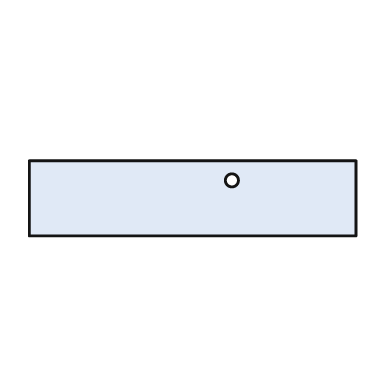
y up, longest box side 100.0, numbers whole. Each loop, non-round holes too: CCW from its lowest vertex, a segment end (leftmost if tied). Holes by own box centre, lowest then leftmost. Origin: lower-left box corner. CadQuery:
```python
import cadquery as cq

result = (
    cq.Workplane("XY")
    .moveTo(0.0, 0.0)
    .lineTo(100.0, 0.0)
    .lineTo(100.0, 23.0)
    .lineTo(0.0, 23.0)
    .close()
    .moveTo(62.0, 17.0)
    .circle(2.0)
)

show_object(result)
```